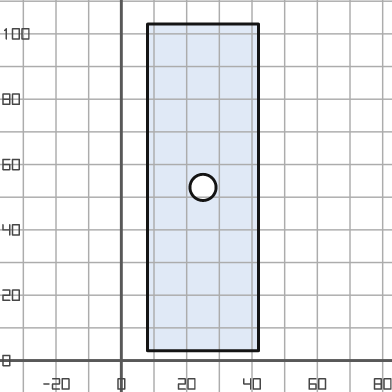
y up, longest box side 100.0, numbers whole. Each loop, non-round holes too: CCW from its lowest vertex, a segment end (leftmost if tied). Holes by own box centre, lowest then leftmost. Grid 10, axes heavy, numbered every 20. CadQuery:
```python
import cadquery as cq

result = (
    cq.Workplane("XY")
    .moveTo(8.0, 3.0)
    .lineTo(42.0, 3.0)
    .lineTo(42.0, 103.0)
    .lineTo(8.0, 103.0)
    .close()
    .moveTo(25.0, 53.0)
    .circle(4.0)
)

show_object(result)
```